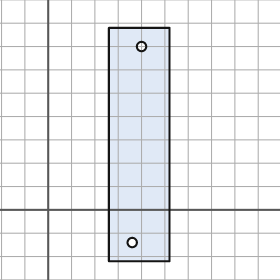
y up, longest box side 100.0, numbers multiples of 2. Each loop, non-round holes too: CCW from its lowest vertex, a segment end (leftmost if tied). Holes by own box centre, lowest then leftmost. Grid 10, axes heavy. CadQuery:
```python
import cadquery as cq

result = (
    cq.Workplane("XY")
    .moveTo(26.0, -22.0)
    .lineTo(52.0, -22.0)
    .lineTo(52.0, 78.0)
    .lineTo(26.0, 78.0)
    .close()
    .moveTo(36.0, -14.0)
    .circle(2.0)
    .moveTo(40.0, 70.0)
    .circle(2.0)
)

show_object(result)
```